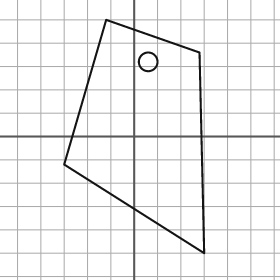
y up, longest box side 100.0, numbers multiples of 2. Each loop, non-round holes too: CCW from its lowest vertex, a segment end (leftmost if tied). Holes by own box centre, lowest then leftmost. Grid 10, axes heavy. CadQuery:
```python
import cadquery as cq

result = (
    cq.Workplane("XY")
    .moveTo(30.0, -50.0)
    .lineTo(28.0, 36.0)
    .lineTo(-12.0, 50.0)
    .lineTo(-30.0, -12.0)
    .close()
    .moveTo(6.0, 32.0)
    .circle(4.0)
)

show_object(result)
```